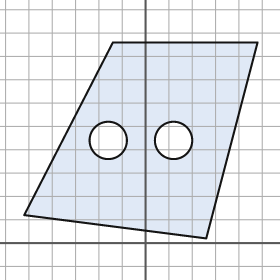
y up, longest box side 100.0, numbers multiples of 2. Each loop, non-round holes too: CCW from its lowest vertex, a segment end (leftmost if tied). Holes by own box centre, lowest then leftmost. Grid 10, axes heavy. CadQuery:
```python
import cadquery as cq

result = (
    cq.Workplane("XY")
    .moveTo(26.0, 2.0)
    .lineTo(48.0, 86.0)
    .lineTo(-14.0, 86.0)
    .lineTo(-52.0, 12.0)
    .close()
    .moveTo(-16.0, 44.0)
    .circle(8.0)
    .moveTo(12.0, 44.0)
    .circle(8.0)
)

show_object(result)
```